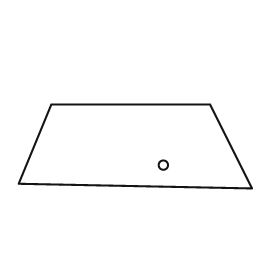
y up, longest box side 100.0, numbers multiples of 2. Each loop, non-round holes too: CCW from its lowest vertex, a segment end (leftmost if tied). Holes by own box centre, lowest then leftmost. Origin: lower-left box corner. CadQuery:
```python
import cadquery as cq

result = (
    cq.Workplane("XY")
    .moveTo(100.0, 0.0)
    .lineTo(82.0, 36.0)
    .lineTo(14.0, 36.0)
    .lineTo(0.0, 2.0)
    .close()
    .moveTo(62.0, 10.0)
    .circle(2.0)
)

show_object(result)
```